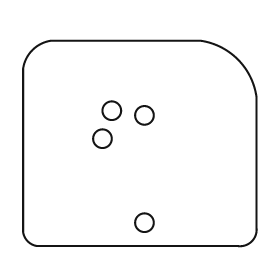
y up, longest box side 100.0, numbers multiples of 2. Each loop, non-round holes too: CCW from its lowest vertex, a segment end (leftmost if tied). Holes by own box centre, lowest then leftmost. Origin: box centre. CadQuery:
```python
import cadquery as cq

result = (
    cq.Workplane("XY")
    .moveTo(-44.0, -44.0)
    .lineTo(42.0, -44.0)
    .threePointArc((48.0, -42.0), (50.0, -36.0))
    .lineTo(50.0, 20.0)
    .threePointArc((42.0, 36.0), (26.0, 44.0))
    .lineTo(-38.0, 44.0)
    .threePointArc((-46.0, 40.0), (-50.0, 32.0))
    .lineTo(-50.0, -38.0)
    .threePointArc((-48.0, -42.0), (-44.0, -44.0))
    .close()
    .moveTo(2.0, -34.0)
    .circle(4.0)
    .moveTo(-16.0, 2.0)
    .circle(4.0)
    .moveTo(2.0, 12.0)
    .circle(4.0)
    .moveTo(-12.0, 14.0)
    .circle(4.0)
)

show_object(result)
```